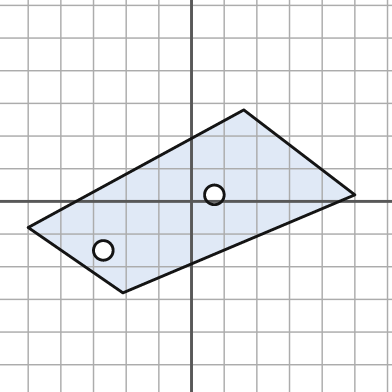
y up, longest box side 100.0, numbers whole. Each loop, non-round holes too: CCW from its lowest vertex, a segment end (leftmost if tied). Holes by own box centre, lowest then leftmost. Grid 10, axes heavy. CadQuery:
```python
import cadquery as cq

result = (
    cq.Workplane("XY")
    .moveTo(-21.0, -28.0)
    .lineTo(50.0, 2.0)
    .lineTo(16.0, 28.0)
    .lineTo(-50.0, -8.0)
    .close()
    .moveTo(-27.0, -15.0)
    .circle(3.0)
    .moveTo(7.0, 2.0)
    .circle(3.0)
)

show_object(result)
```